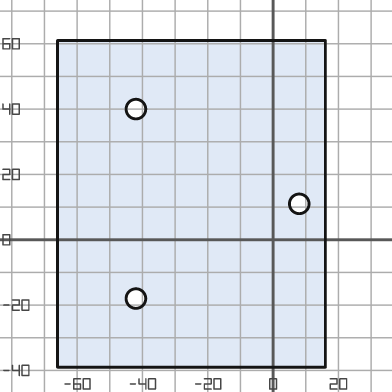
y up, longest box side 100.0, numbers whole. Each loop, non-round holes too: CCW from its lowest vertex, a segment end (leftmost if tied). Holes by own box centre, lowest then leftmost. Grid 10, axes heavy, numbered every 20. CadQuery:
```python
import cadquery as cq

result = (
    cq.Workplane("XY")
    .moveTo(-66.0, -39.0)
    .lineTo(16.0, -39.0)
    .lineTo(16.0, 61.0)
    .lineTo(-66.0, 61.0)
    .close()
    .moveTo(-42.0, -18.0)
    .circle(3.0)
    .moveTo(8.0, 11.0)
    .circle(3.0)
    .moveTo(-42.0, 40.0)
    .circle(3.0)
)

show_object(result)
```